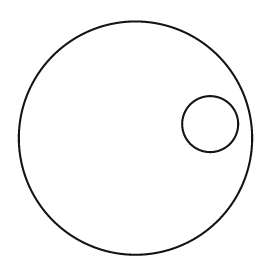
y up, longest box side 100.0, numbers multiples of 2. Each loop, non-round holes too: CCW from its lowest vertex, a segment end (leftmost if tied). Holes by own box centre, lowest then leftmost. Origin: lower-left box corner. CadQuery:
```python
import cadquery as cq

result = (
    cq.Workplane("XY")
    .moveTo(50.0, 50.0)
    .circle(50.0)
    .moveTo(82.0, 56.0)
    .circle(12.0)
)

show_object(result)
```